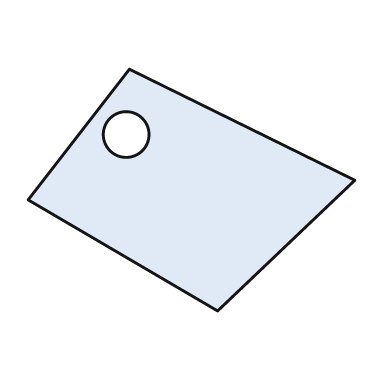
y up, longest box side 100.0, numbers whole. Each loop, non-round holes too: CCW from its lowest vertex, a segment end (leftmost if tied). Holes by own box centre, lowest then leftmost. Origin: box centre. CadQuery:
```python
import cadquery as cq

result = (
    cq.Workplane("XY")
    .moveTo(8.0, -37.0)
    .lineTo(50.0, 3.0)
    .lineTo(-19.0, 37.0)
    .lineTo(-50.0, -3.0)
    .close()
    .moveTo(-20.0, 17.0)
    .circle(7.0)
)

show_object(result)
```